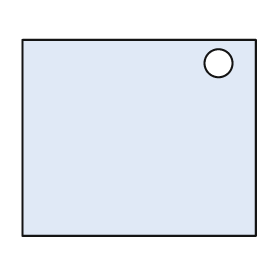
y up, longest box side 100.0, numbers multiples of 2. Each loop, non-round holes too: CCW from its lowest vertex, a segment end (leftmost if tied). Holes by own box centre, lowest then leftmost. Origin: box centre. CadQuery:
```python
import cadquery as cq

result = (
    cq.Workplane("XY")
    .moveTo(-50.0, -42.0)
    .lineTo(50.0, -42.0)
    .lineTo(50.0, 42.0)
    .lineTo(-50.0, 42.0)
    .close()
    .moveTo(34.0, 32.0)
    .circle(6.0)
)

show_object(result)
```